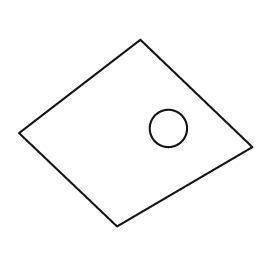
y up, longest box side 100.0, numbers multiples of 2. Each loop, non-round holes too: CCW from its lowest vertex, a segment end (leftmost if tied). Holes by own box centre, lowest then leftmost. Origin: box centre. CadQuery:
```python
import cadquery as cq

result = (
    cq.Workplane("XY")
    .moveTo(-8.0, -40.0)
    .lineTo(50.0, -6.0)
    .lineTo(2.0, 40.0)
    .lineTo(-50.0, 0.0)
    .close()
    .moveTo(14.0, 2.0)
    .circle(8.0)
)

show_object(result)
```